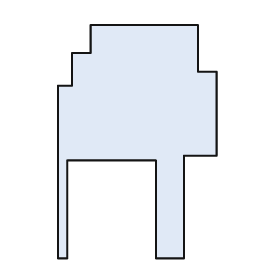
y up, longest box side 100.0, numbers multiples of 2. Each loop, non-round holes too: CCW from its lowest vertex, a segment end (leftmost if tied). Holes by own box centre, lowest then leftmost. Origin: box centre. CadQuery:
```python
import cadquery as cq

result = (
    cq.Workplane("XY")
    .moveTo(-34.0, -50.0)
    .lineTo(-30.0, -50.0)
    .lineTo(-30.0, -8.0)
    .lineTo(8.0, -8.0)
    .lineTo(8.0, -50.0)
    .lineTo(20.0, -50.0)
    .lineTo(20.0, -6.0)
    .lineTo(34.0, -6.0)
    .lineTo(34.0, 30.0)
    .lineTo(26.0, 30.0)
    .lineTo(26.0, 50.0)
    .lineTo(-20.0, 50.0)
    .lineTo(-20.0, 38.0)
    .lineTo(-28.0, 38.0)
    .lineTo(-28.0, 24.0)
    .lineTo(-34.0, 24.0)
    .close()
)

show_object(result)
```